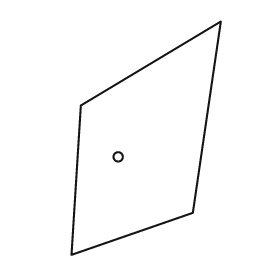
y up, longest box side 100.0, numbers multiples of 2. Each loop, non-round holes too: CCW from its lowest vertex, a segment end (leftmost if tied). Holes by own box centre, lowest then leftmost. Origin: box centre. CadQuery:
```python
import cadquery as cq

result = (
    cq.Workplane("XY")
    .moveTo(-32.0, -50.0)
    .lineTo(20.0, -32.0)
    .lineTo(32.0, 50.0)
    .lineTo(-28.0, 14.0)
    .close()
    .moveTo(-12.0, -8.0)
    .circle(2.0)
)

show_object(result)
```